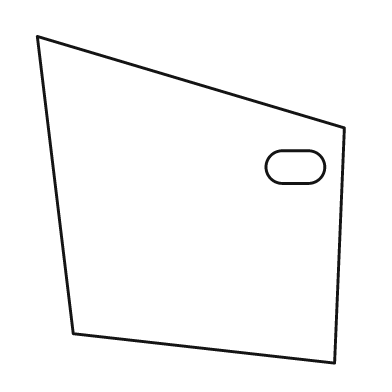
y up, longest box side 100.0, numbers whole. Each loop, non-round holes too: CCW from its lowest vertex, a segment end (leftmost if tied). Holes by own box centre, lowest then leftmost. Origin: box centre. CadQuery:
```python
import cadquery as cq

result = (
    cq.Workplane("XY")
    .moveTo(44.0, -50.0)
    .lineTo(47.0, 22.0)
    .lineTo(-47.0, 50.0)
    .lineTo(-36.0, -41.0)
    .close()
    .moveTo(28.0, 5.0)
    .lineTo(36.0, 5.0)
    .threePointArc((41.0, 10.0), (36.0, 15.0))
    .lineTo(28.0, 15.0)
    .threePointArc((23.0, 10.0), (28.0, 5.0))
    .close()
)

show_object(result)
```